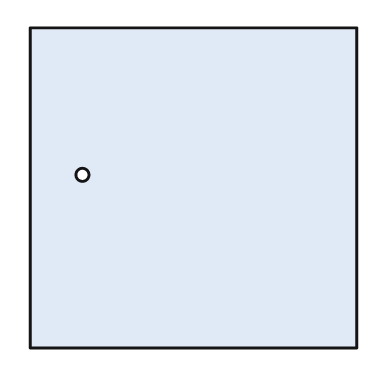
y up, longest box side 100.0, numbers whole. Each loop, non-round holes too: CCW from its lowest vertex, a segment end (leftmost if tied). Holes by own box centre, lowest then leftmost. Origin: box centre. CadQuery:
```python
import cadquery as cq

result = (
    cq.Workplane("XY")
    .moveTo(-50.0, -49.0)
    .lineTo(50.0, -49.0)
    .lineTo(50.0, 49.0)
    .lineTo(-50.0, 49.0)
    .close()
    .moveTo(-34.0, 4.0)
    .circle(2.0)
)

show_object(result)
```